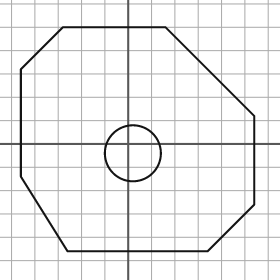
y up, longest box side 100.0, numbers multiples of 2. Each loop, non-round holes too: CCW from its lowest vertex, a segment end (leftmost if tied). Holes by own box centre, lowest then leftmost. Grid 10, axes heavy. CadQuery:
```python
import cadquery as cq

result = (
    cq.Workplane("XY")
    .moveTo(-26.0, -46.0)
    .lineTo(34.0, -46.0)
    .lineTo(54.0, -26.0)
    .lineTo(54.0, 12.0)
    .lineTo(16.0, 50.0)
    .lineTo(-28.0, 50.0)
    .lineTo(-46.0, 32.0)
    .lineTo(-46.0, -14.0)
    .close()
    .moveTo(2.0, -4.0)
    .circle(12.0)
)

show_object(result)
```